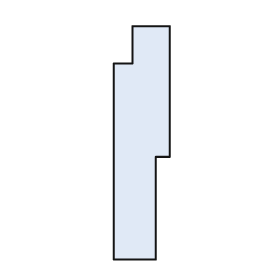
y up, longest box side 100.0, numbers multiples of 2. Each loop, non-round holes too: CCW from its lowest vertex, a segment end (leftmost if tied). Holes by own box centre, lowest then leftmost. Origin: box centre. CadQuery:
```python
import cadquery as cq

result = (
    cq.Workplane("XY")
    .moveTo(-12.0, -50.0)
    .lineTo(6.0, -50.0)
    .lineTo(6.0, -6.0)
    .lineTo(12.0, -6.0)
    .lineTo(12.0, 50.0)
    .lineTo(-4.0, 50.0)
    .lineTo(-4.0, 34.0)
    .lineTo(-12.0, 34.0)
    .close()
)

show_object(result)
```